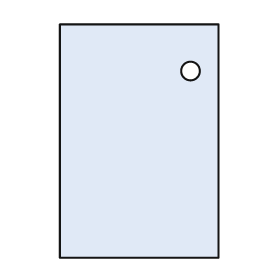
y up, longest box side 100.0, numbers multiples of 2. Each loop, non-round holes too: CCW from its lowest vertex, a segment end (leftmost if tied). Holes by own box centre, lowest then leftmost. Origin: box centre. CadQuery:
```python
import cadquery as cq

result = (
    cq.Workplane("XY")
    .moveTo(-34.0, -50.0)
    .lineTo(34.0, -50.0)
    .lineTo(34.0, 50.0)
    .lineTo(-34.0, 50.0)
    .close()
    .moveTo(22.0, 30.0)
    .circle(4.0)
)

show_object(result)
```